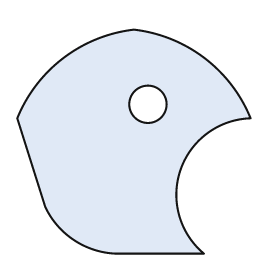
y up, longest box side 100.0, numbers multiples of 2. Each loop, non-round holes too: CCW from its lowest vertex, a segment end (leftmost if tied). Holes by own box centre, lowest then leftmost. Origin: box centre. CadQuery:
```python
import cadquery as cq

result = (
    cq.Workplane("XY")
    .moveTo(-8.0, -48.0)
    .lineTo(30.0, -48.0)
    .threePointArc((20.0, -12.0), (50.0, 10.0))
    .threePointArc((30.0, 36.0), (0.0, 48.0))
    .threePointArc((-30.0, 36.0), (-50.0, 10.0))
    .lineTo(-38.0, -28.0)
    .threePointArc((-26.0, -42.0), (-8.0, -48.0))
    .close()
    .moveTo(6.0, 16.0)
    .circle(8.0)
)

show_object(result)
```